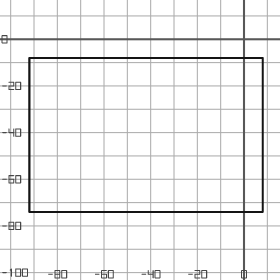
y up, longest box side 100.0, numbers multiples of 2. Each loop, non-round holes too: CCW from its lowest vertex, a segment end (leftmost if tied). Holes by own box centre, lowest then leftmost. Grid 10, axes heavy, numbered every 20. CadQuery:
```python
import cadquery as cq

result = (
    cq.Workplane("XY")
    .moveTo(-92.0, -74.0)
    .lineTo(8.0, -74.0)
    .lineTo(8.0, -8.0)
    .lineTo(-92.0, -8.0)
    .close()
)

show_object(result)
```